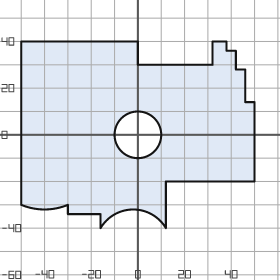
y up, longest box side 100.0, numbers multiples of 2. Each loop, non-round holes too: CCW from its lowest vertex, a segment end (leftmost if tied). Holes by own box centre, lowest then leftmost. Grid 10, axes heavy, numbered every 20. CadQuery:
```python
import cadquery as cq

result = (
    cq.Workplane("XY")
    .moveTo(-16.0, -40.0)
    .threePointArc((-2.0, -32.0), (12.0, -40.0))
    .lineTo(12.0, -20.0)
    .lineTo(50.0, -20.0)
    .lineTo(50.0, 14.0)
    .lineTo(46.0, 14.0)
    .lineTo(46.0, 28.0)
    .lineTo(42.0, 28.0)
    .lineTo(42.0, 36.0)
    .lineTo(38.0, 36.0)
    .lineTo(38.0, 40.0)
    .lineTo(32.0, 40.0)
    .lineTo(32.0, 30.0)
    .lineTo(0.0, 30.0)
    .lineTo(0.0, 40.0)
    .lineTo(-50.0, 40.0)
    .lineTo(-50.0, -30.0)
    .threePointArc((-40.0, -32.0), (-30.0, -30.0))
    .lineTo(-30.0, -34.0)
    .lineTo(-16.0, -34.0)
    .close()
    .moveTo(0.0, 0.0)
    .circle(10.0)
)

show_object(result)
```